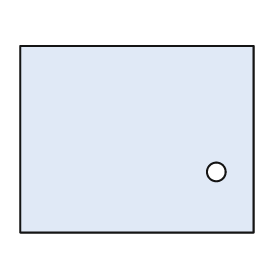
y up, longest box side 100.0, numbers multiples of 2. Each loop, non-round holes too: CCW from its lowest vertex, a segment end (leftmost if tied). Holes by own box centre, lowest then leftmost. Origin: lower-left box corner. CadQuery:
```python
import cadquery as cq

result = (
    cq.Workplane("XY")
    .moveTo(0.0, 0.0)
    .lineTo(100.0, 0.0)
    .lineTo(100.0, 80.0)
    .lineTo(0.0, 80.0)
    .close()
    .moveTo(84.0, 26.0)
    .circle(4.0)
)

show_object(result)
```